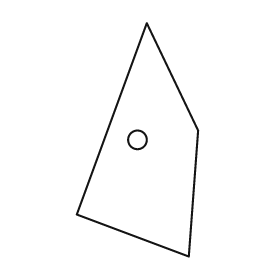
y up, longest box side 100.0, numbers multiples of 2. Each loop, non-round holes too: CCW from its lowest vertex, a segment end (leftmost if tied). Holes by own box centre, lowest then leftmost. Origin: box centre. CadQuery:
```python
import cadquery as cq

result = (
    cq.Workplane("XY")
    .moveTo(22.0, -50.0)
    .lineTo(26.0, 4.0)
    .lineTo(4.0, 50.0)
    .lineTo(-26.0, -32.0)
    .close()
    .moveTo(0.0, 0.0)
    .circle(4.0)
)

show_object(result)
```